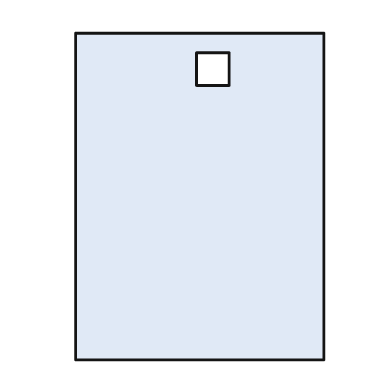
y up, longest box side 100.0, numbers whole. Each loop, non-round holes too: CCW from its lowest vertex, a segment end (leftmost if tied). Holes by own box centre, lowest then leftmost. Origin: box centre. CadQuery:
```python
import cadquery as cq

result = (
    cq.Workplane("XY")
    .moveTo(-38.0, -50.0)
    .lineTo(38.0, -50.0)
    .lineTo(38.0, 50.0)
    .lineTo(-38.0, 50.0)
    .close()
    .moveTo(-1.0, 34.0)
    .lineTo(9.0, 34.0)
    .lineTo(9.0, 44.0)
    .lineTo(-1.0, 44.0)
    .close()
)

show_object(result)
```